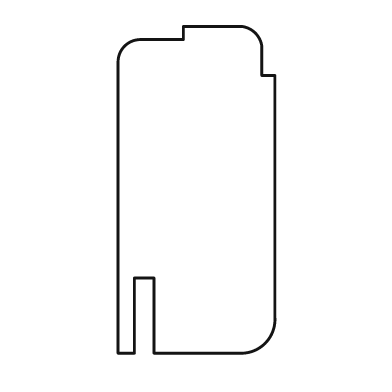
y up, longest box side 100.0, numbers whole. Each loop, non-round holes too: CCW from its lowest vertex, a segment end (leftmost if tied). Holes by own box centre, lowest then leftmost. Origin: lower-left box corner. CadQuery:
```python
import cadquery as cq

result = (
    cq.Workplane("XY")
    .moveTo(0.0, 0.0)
    .lineTo(5.0, 0.0)
    .lineTo(5.0, 23.0)
    .lineTo(11.0, 23.0)
    .lineTo(11.0, 0.0)
    .lineTo(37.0, 0.0)
    .threePointArc((45.0, 3.0), (48.0, 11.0))
    .lineTo(48.0, 85.0)
    .lineTo(44.0, 85.0)
    .lineTo(44.0, 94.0)
    .threePointArc((42.0, 98.0), (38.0, 100.0))
    .lineTo(20.0, 100.0)
    .lineTo(20.0, 96.0)
    .lineTo(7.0, 96.0)
    .threePointArc((2.0, 94.0), (0.0, 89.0))
    .close()
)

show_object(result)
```